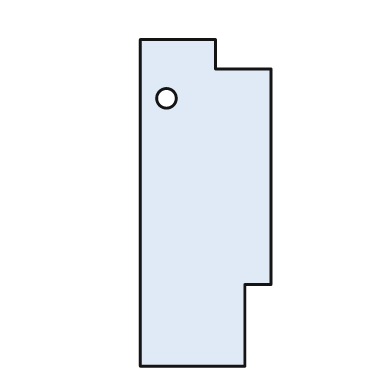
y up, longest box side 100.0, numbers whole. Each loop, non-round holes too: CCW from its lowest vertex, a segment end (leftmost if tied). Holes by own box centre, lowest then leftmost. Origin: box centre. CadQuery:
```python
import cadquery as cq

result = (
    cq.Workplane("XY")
    .moveTo(-20.0, -50.0)
    .lineTo(12.0, -50.0)
    .lineTo(12.0, -25.0)
    .lineTo(20.0, -25.0)
    .lineTo(20.0, 41.0)
    .lineTo(3.0, 41.0)
    .lineTo(3.0, 50.0)
    .lineTo(-20.0, 50.0)
    .close()
    .moveTo(-12.0, 32.0)
    .circle(3.0)
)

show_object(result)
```